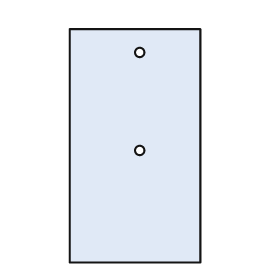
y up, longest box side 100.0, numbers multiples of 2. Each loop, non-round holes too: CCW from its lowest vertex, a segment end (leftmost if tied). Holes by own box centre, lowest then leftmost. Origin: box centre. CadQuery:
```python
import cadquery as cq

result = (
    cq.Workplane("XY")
    .moveTo(-28.0, -50.0)
    .lineTo(28.0, -50.0)
    .lineTo(28.0, 50.0)
    .lineTo(-28.0, 50.0)
    .close()
    .moveTo(2.0, -2.0)
    .circle(2.0)
    .moveTo(2.0, 40.0)
    .circle(2.0)
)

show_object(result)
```